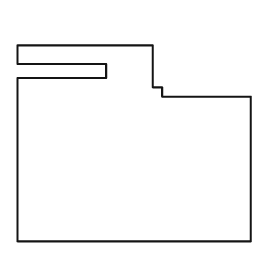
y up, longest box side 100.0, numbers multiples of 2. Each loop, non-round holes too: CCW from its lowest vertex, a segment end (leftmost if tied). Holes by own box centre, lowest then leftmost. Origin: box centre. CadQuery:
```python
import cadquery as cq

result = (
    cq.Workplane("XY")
    .moveTo(-50.0, -42.0)
    .lineTo(50.0, -42.0)
    .lineTo(50.0, 20.0)
    .lineTo(12.0, 20.0)
    .lineTo(12.0, 24.0)
    .lineTo(8.0, 24.0)
    .lineTo(8.0, 42.0)
    .lineTo(-50.0, 42.0)
    .lineTo(-50.0, 34.0)
    .lineTo(-12.0, 34.0)
    .lineTo(-12.0, 28.0)
    .lineTo(-50.0, 28.0)
    .close()
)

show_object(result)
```